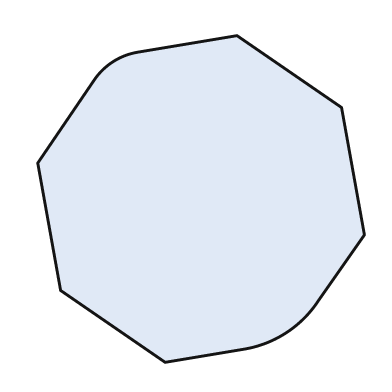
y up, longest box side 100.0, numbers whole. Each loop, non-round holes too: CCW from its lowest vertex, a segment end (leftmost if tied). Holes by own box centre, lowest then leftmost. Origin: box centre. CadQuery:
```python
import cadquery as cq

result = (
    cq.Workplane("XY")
    .moveTo(-11.0, -50.0)
    .lineTo(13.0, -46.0)
    .threePointArc((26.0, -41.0), (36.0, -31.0))
    .lineTo(50.0, -11.0)
    .lineTo(43.0, 28.0)
    .lineTo(11.0, 50.0)
    .lineTo(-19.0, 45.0)
    .threePointArc((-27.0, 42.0), (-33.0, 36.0))
    .lineTo(-50.0, 11.0)
    .lineTo(-43.0, -28.0)
    .close()
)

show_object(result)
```